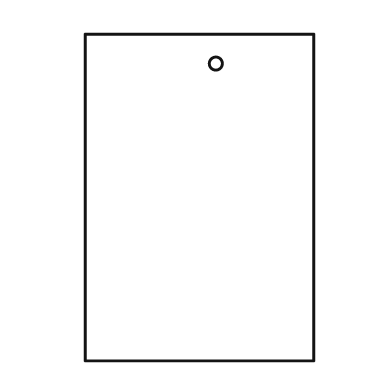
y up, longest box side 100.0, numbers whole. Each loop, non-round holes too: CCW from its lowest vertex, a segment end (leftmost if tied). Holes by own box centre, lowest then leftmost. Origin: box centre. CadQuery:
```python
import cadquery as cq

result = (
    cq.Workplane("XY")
    .moveTo(-35.0, -50.0)
    .lineTo(35.0, -50.0)
    .lineTo(35.0, 50.0)
    .lineTo(-35.0, 50.0)
    .close()
    .moveTo(5.0, 41.0)
    .circle(2.0)
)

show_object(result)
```